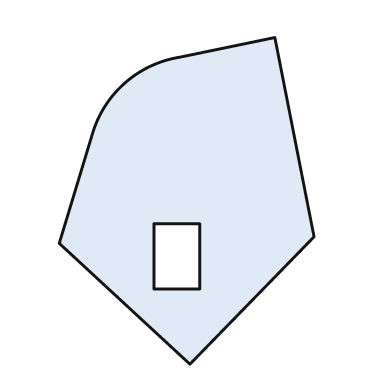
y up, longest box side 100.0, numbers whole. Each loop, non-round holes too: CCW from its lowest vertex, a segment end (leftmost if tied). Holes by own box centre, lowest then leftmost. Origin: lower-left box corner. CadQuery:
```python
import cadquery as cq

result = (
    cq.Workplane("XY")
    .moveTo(40.0, 0.0)
    .lineTo(78.0, 39.0)
    .lineTo(66.0, 100.0)
    .lineTo(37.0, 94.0)
    .threePointArc((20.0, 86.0), (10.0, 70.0))
    .lineTo(0.0, 37.0)
    .close()
    .moveTo(29.0, 23.0)
    .lineTo(43.0, 23.0)
    .lineTo(43.0, 43.0)
    .lineTo(29.0, 43.0)
    .close()
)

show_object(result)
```